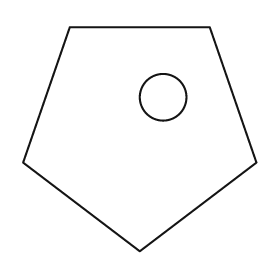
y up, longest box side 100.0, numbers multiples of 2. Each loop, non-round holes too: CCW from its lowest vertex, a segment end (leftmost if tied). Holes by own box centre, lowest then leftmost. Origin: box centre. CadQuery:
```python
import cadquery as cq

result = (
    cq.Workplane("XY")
    .moveTo(0.0, -48.0)
    .lineTo(50.0, -10.0)
    .lineTo(30.0, 48.0)
    .lineTo(-30.0, 48.0)
    .lineTo(-50.0, -10.0)
    .close()
    .moveTo(10.0, 18.0)
    .circle(10.0)
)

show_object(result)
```